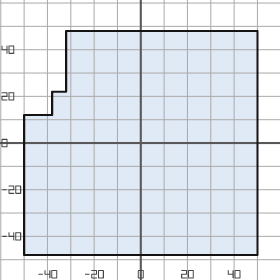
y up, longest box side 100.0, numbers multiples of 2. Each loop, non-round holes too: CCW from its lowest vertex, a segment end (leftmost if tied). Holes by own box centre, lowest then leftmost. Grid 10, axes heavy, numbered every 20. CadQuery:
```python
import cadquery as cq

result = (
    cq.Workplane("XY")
    .moveTo(-50.0, -48.0)
    .lineTo(50.0, -48.0)
    .lineTo(50.0, 48.0)
    .lineTo(-32.0, 48.0)
    .lineTo(-32.0, 22.0)
    .lineTo(-38.0, 22.0)
    .lineTo(-38.0, 12.0)
    .lineTo(-50.0, 12.0)
    .close()
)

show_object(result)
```